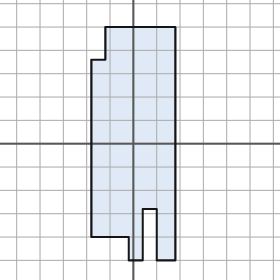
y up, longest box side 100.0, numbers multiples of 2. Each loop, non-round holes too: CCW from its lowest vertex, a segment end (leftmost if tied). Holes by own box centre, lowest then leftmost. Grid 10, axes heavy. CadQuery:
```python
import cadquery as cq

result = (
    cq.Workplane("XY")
    .moveTo(-2.0, -50.0)
    .lineTo(4.0, -50.0)
    .lineTo(4.0, -28.0)
    .lineTo(10.0, -28.0)
    .lineTo(10.0, -50.0)
    .lineTo(18.0, -50.0)
    .lineTo(18.0, 50.0)
    .lineTo(-12.0, 50.0)
    .lineTo(-12.0, 36.0)
    .lineTo(-18.0, 36.0)
    .lineTo(-18.0, -40.0)
    .lineTo(-2.0, -40.0)
    .close()
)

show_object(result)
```